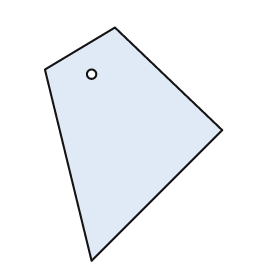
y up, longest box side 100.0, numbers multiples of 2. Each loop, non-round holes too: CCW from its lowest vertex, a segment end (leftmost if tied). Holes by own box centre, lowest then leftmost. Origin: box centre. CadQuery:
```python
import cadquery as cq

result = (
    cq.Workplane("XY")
    .moveTo(-18.0, -50.0)
    .lineTo(38.0, 6.0)
    .lineTo(-8.0, 50.0)
    .lineTo(-38.0, 32.0)
    .close()
    .moveTo(-18.0, 30.0)
    .circle(2.0)
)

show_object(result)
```